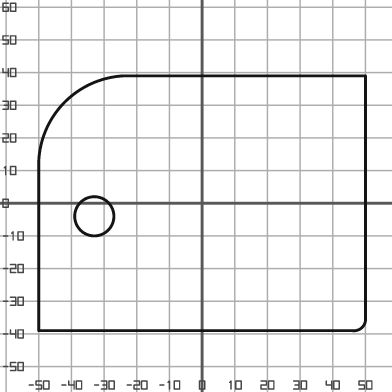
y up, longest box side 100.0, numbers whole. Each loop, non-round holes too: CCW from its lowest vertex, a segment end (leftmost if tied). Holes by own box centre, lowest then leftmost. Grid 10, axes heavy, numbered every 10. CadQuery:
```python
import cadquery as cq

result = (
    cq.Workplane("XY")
    .moveTo(-50.0, -39.0)
    .lineTo(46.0, -39.0)
    .threePointArc((49.0, -38.0), (50.0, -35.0))
    .lineTo(50.0, 39.0)
    .lineTo(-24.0, 39.0)
    .threePointArc((-42.0, 31.0), (-50.0, 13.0))
    .close()
    .moveTo(-33.0, -4.0)
    .circle(6.0)
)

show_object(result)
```